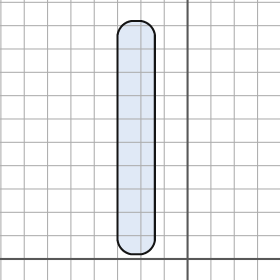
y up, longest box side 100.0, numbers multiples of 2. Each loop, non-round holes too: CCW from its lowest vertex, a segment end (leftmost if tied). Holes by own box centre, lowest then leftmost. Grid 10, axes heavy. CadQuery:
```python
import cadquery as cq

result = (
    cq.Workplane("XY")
    .moveTo(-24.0, 2.0)
    .lineTo(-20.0, 2.0)
    .threePointArc((-16.0, 4.0), (-14.0, 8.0))
    .lineTo(-14.0, 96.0)
    .threePointArc((-16.0, 100.0), (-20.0, 102.0))
    .lineTo(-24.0, 102.0)
    .threePointArc((-28.0, 100.0), (-30.0, 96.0))
    .lineTo(-30.0, 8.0)
    .threePointArc((-28.0, 4.0), (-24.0, 2.0))
    .close()
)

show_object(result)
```